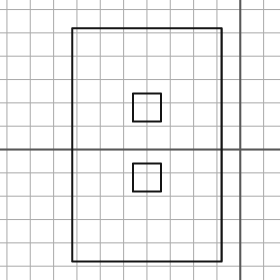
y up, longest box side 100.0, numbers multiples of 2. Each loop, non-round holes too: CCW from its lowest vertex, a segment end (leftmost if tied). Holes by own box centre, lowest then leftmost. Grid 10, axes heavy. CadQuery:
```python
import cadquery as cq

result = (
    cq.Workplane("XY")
    .moveTo(-72.0, -48.0)
    .lineTo(-8.0, -48.0)
    .lineTo(-8.0, 52.0)
    .lineTo(-72.0, 52.0)
    .close()
    .moveTo(-46.0, -18.0)
    .lineTo(-34.0, -18.0)
    .lineTo(-34.0, -6.0)
    .lineTo(-46.0, -6.0)
    .close()
    .moveTo(-46.0, 12.0)
    .lineTo(-34.0, 12.0)
    .lineTo(-34.0, 24.0)
    .lineTo(-46.0, 24.0)
    .close()
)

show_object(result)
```